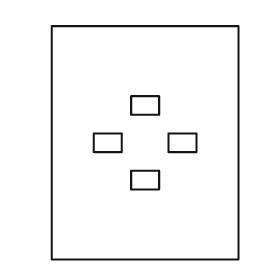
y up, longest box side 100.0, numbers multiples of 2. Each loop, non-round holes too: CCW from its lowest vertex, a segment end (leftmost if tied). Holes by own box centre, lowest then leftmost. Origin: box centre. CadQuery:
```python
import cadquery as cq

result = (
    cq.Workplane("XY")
    .moveTo(-40.0, -50.0)
    .lineTo(40.0, -50.0)
    .lineTo(40.0, 50.0)
    .lineTo(-40.0, 50.0)
    .close()
    .moveTo(-6.0, -20.0)
    .lineTo(6.0, -20.0)
    .lineTo(6.0, -12.0)
    .lineTo(-6.0, -12.0)
    .close()
    .moveTo(-22.0, -4.0)
    .lineTo(-10.0, -4.0)
    .lineTo(-10.0, 4.0)
    .lineTo(-22.0, 4.0)
    .close()
    .moveTo(10.0, -4.0)
    .lineTo(22.0, -4.0)
    .lineTo(22.0, 4.0)
    .lineTo(10.0, 4.0)
    .close()
    .moveTo(-6.0, 12.0)
    .lineTo(6.0, 12.0)
    .lineTo(6.0, 20.0)
    .lineTo(-6.0, 20.0)
    .close()
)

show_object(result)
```